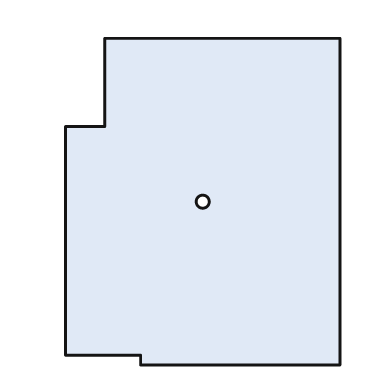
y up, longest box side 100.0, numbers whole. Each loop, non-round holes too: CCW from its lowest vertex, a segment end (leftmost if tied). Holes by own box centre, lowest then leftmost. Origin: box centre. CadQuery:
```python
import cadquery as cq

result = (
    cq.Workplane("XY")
    .moveTo(-19.0, -50.0)
    .lineTo(42.0, -50.0)
    .lineTo(42.0, 50.0)
    .lineTo(-30.0, 50.0)
    .lineTo(-30.0, 23.0)
    .lineTo(-42.0, 23.0)
    .lineTo(-42.0, -47.0)
    .lineTo(-19.0, -47.0)
    .close()
    .moveTo(0.0, 0.0)
    .circle(2.0)
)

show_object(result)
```